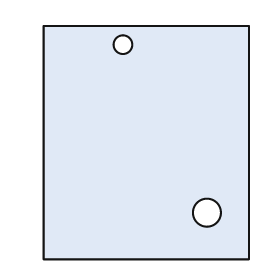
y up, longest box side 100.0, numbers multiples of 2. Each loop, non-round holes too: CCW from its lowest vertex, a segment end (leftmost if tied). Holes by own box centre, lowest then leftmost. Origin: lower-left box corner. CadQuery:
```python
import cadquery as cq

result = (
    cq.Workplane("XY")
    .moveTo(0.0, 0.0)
    .lineTo(88.0, 0.0)
    .lineTo(88.0, 100.0)
    .lineTo(0.0, 100.0)
    .close()
    .moveTo(70.0, 20.0)
    .circle(6.0)
    .moveTo(34.0, 92.0)
    .circle(4.0)
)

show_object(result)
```